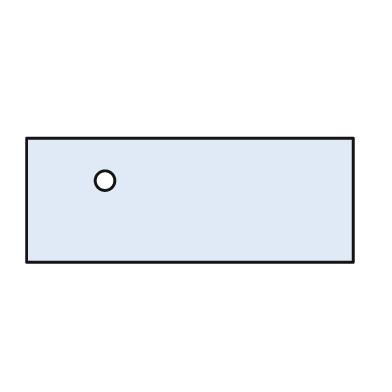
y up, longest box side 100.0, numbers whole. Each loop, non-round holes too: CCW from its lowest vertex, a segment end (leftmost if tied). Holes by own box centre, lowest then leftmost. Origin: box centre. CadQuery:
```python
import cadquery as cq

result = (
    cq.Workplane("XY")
    .moveTo(-50.0, -19.0)
    .lineTo(50.0, -19.0)
    .lineTo(50.0, 19.0)
    .lineTo(-50.0, 19.0)
    .close()
    .moveTo(-26.0, 6.0)
    .circle(3.0)
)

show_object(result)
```